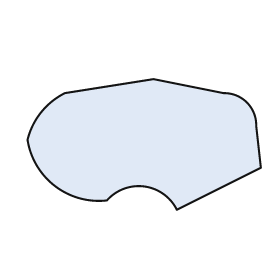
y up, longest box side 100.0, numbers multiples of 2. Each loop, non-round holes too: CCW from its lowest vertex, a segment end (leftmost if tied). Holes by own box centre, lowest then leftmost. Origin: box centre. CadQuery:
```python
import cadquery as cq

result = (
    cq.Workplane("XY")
    .moveTo(14.0, -28.0)
    .lineTo(50.0, -10.0)
    .lineTo(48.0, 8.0)
    .threePointArc((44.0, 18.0), (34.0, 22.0))
    .lineTo(4.0, 28.0)
    .lineTo(-34.0, 22.0)
    .threePointArc((-44.0, 14.0), (-50.0, 2.0))
    .threePointArc((-38.0, -18.0), (-16.0, -24.0))
    .threePointArc((0.0, -18.0), (14.0, -28.0))
    .close()
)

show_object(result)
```